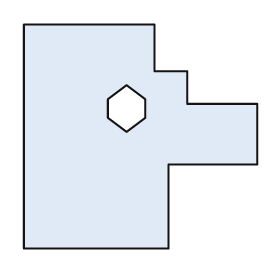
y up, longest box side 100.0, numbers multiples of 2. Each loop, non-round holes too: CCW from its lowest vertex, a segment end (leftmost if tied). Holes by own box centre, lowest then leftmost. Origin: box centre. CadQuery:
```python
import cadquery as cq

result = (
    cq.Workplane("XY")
    .moveTo(-50.0, -48.0)
    .lineTo(12.0, -48.0)
    .lineTo(12.0, -12.0)
    .lineTo(50.0, -12.0)
    .lineTo(50.0, 14.0)
    .lineTo(20.0, 14.0)
    .lineTo(20.0, 28.0)
    .lineTo(6.0, 28.0)
    .lineTo(6.0, 48.0)
    .lineTo(-50.0, 48.0)
    .close()
    .moveTo(-6.0, 2.0)
    .lineTo(2.0, 8.0)
    .lineTo(2.0, 16.0)
    .lineTo(-6.0, 22.0)
    .lineTo(-14.0, 16.0)
    .lineTo(-14.0, 8.0)
    .close()
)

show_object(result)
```